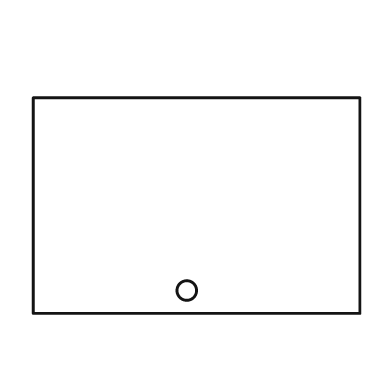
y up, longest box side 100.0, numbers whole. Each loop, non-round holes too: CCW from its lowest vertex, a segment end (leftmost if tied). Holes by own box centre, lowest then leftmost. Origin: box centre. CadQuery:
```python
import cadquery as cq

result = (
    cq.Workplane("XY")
    .moveTo(-50.0, -33.0)
    .lineTo(50.0, -33.0)
    .lineTo(50.0, 33.0)
    .lineTo(-50.0, 33.0)
    .close()
    .moveTo(-3.0, -26.0)
    .circle(3.0)
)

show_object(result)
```